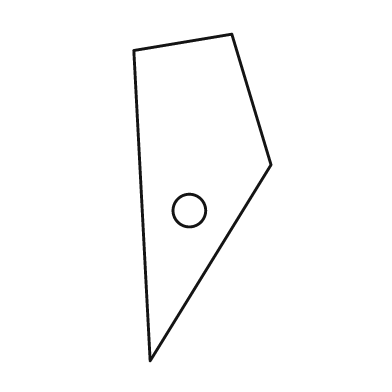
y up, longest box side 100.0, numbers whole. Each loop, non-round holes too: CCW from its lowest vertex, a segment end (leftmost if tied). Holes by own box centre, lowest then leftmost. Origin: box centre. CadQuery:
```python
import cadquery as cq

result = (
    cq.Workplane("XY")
    .moveTo(-16.0, -50.0)
    .lineTo(21.0, 10.0)
    .lineTo(9.0, 50.0)
    .lineTo(-21.0, 45.0)
    .close()
    .moveTo(-4.0, -4.0)
    .circle(5.0)
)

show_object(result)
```